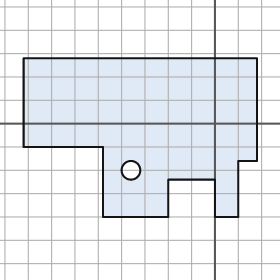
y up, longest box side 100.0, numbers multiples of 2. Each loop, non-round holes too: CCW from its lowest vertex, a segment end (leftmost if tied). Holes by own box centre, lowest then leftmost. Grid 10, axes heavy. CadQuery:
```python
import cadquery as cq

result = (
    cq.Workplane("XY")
    .moveTo(-48.0, -40.0)
    .lineTo(-20.0, -40.0)
    .lineTo(-20.0, -24.0)
    .lineTo(0.0, -24.0)
    .lineTo(0.0, -40.0)
    .lineTo(10.0, -40.0)
    .lineTo(10.0, -16.0)
    .lineTo(18.0, -16.0)
    .lineTo(18.0, 28.0)
    .lineTo(-82.0, 28.0)
    .lineTo(-82.0, -10.0)
    .lineTo(-48.0, -10.0)
    .close()
    .moveTo(-36.0, -20.0)
    .circle(4.0)
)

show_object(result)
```